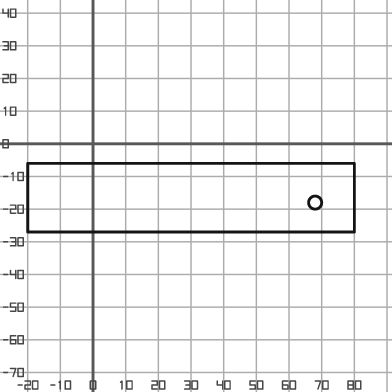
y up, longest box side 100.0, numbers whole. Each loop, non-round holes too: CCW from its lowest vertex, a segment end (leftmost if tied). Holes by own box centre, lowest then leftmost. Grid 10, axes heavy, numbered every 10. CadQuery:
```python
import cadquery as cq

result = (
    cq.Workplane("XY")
    .moveTo(-20.0, -27.0)
    .lineTo(80.0, -27.0)
    .lineTo(80.0, -6.0)
    .lineTo(-20.0, -6.0)
    .close()
    .moveTo(68.0, -18.0)
    .circle(2.0)
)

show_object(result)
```